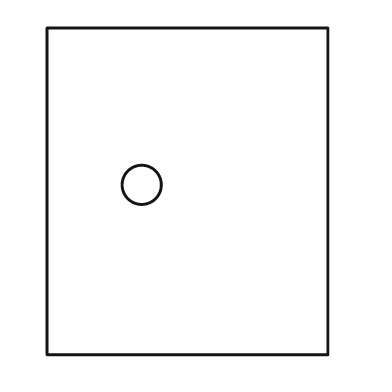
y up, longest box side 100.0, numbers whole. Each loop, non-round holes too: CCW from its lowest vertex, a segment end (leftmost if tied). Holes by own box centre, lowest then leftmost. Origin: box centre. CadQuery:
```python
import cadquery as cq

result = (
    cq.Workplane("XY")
    .moveTo(-43.0, -50.0)
    .lineTo(43.0, -50.0)
    .lineTo(43.0, 50.0)
    .lineTo(-43.0, 50.0)
    .close()
    .moveTo(-14.0, 2.0)
    .circle(6.0)
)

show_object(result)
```